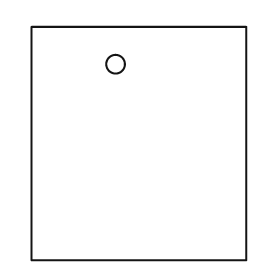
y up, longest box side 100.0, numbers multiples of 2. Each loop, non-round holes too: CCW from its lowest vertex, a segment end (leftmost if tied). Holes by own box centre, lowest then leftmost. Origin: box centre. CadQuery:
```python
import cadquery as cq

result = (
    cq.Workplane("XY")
    .moveTo(-46.0, -50.0)
    .lineTo(46.0, -50.0)
    .lineTo(46.0, 50.0)
    .lineTo(-46.0, 50.0)
    .close()
    .moveTo(-10.0, 34.0)
    .circle(4.0)
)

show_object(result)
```